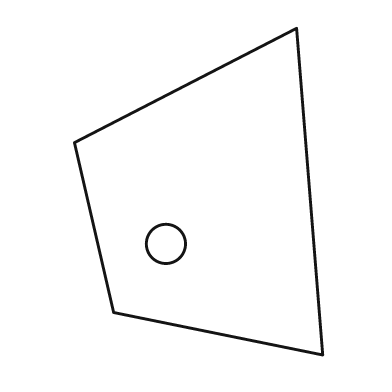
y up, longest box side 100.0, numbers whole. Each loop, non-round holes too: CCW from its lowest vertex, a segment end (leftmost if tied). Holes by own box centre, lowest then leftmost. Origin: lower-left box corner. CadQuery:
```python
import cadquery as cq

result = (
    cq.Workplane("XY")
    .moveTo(76.0, 0.0)
    .lineTo(68.0, 100.0)
    .lineTo(0.0, 65.0)
    .lineTo(12.0, 13.0)
    .close()
    .moveTo(28.0, 34.0)
    .circle(6.0)
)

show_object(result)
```